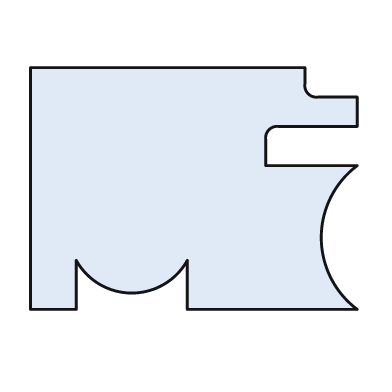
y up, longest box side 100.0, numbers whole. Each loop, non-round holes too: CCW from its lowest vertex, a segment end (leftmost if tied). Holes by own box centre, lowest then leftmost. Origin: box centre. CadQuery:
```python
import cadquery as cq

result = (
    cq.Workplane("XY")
    .moveTo(-50.0, -37.0)
    .lineTo(-36.0, -37.0)
    .lineTo(-36.0, -22.0)
    .threePointArc((-19.0, -32.0), (-2.0, -22.0))
    .lineTo(-2.0, -37.0)
    .lineTo(50.0, -37.0)
    .threePointArc((39.0, -15.0), (50.0, 7.0))
    .lineTo(22.0, 7.0)
    .lineTo(22.0, 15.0)
    .threePointArc((23.0, 18.0), (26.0, 19.0))
    .lineTo(50.0, 19.0)
    .lineTo(50.0, 28.0)
    .lineTo(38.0, 28.0)
    .threePointArc((35.0, 29.0), (34.0, 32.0))
    .lineTo(34.0, 37.0)
    .lineTo(-50.0, 37.0)
    .close()
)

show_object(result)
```